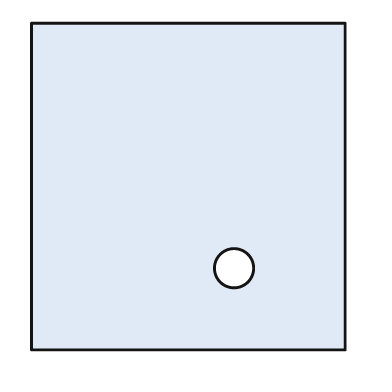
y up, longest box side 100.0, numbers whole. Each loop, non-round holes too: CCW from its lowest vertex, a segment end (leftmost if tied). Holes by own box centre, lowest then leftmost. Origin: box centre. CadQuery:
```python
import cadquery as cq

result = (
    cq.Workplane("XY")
    .moveTo(-48.0, -50.0)
    .lineTo(48.0, -50.0)
    .lineTo(48.0, 50.0)
    .lineTo(-48.0, 50.0)
    .close()
    .moveTo(14.0, -25.0)
    .circle(6.0)
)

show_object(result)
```